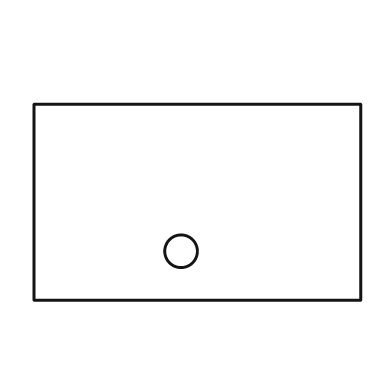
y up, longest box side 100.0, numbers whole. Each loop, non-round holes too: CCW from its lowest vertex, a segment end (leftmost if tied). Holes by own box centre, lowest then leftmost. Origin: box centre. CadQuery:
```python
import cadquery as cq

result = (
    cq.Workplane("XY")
    .moveTo(-50.0, -30.0)
    .lineTo(50.0, -30.0)
    .lineTo(50.0, 30.0)
    .lineTo(-50.0, 30.0)
    .close()
    .moveTo(-5.0, -15.0)
    .circle(5.0)
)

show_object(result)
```